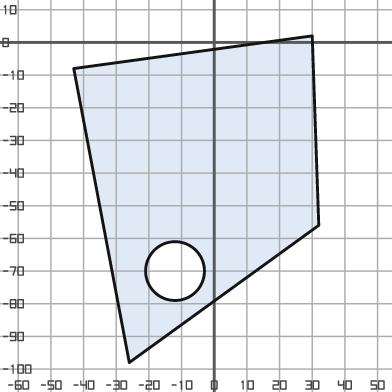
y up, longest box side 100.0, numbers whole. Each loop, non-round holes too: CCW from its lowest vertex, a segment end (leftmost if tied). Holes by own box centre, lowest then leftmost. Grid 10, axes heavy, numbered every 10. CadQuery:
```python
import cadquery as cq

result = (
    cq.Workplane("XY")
    .moveTo(-26.0, -98.0)
    .lineTo(32.0, -56.0)
    .lineTo(30.0, 2.0)
    .lineTo(-43.0, -8.0)
    .close()
    .moveTo(-12.0, -70.0)
    .circle(9.0)
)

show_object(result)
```